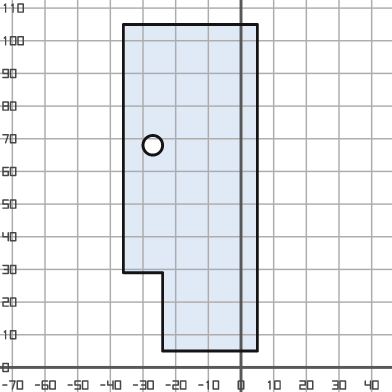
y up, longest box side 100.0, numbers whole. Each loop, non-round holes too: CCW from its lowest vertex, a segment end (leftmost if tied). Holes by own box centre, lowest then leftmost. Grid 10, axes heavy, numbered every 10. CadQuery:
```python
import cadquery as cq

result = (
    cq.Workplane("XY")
    .moveTo(-24.0, 5.0)
    .lineTo(5.0, 5.0)
    .lineTo(5.0, 105.0)
    .lineTo(-36.0, 105.0)
    .lineTo(-36.0, 29.0)
    .lineTo(-24.0, 29.0)
    .close()
    .moveTo(-27.0, 68.0)
    .circle(3.0)
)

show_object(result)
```